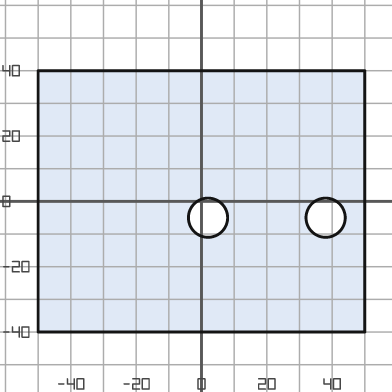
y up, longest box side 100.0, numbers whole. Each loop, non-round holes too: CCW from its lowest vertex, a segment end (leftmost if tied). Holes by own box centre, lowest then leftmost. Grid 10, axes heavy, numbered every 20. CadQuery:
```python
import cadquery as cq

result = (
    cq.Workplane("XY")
    .moveTo(-50.0, -40.0)
    .lineTo(50.0, -40.0)
    .lineTo(50.0, 40.0)
    .lineTo(-50.0, 40.0)
    .close()
    .moveTo(2.0, -5.0)
    .circle(6.0)
    .moveTo(38.0, -5.0)
    .circle(6.0)
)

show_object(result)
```